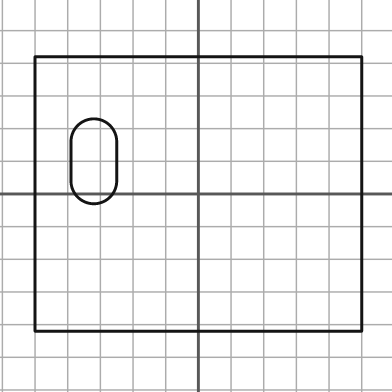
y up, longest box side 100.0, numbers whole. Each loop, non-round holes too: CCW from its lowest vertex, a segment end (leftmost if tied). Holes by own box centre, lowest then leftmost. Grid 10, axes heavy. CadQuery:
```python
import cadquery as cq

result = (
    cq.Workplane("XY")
    .moveTo(-50.0, -42.0)
    .lineTo(50.0, -42.0)
    .lineTo(50.0, 42.0)
    .lineTo(-50.0, 42.0)
    .close()
    .moveTo(-39.0, 4.0)
    .threePointArc((-32.0, -3.0), (-25.0, 4.0))
    .lineTo(-25.0, 16.0)
    .threePointArc((-32.0, 23.0), (-39.0, 16.0))
    .close()
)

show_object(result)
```